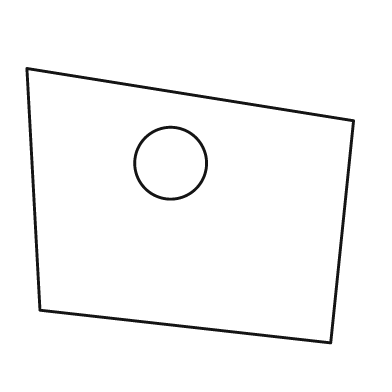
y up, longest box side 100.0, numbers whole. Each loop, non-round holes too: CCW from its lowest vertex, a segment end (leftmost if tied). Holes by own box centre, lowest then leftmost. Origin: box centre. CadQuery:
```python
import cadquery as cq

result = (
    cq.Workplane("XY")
    .moveTo(43.0, -42.0)
    .lineTo(50.0, 26.0)
    .lineTo(-50.0, 42.0)
    .lineTo(-46.0, -32.0)
    .close()
    .moveTo(-6.0, 13.0)
    .circle(11.0)
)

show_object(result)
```